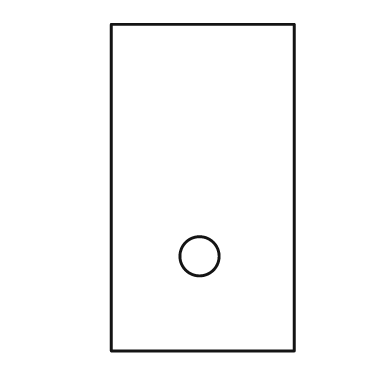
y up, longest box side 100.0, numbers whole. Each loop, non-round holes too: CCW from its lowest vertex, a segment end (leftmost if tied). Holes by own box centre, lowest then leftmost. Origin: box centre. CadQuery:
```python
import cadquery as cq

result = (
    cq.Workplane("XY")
    .moveTo(-28.0, -50.0)
    .lineTo(28.0, -50.0)
    .lineTo(28.0, 50.0)
    .lineTo(-28.0, 50.0)
    .close()
    .moveTo(-1.0, -21.0)
    .circle(6.0)
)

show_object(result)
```